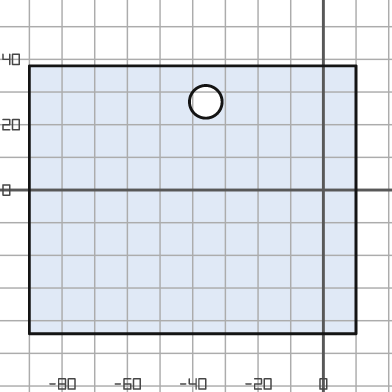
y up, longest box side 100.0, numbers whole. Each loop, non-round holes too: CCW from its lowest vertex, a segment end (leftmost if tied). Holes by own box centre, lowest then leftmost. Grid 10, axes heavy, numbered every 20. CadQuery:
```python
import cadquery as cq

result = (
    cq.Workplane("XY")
    .moveTo(-90.0, -44.0)
    .lineTo(10.0, -44.0)
    .lineTo(10.0, 38.0)
    .lineTo(-90.0, 38.0)
    .close()
    .moveTo(-36.0, 27.0)
    .circle(5.0)
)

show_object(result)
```